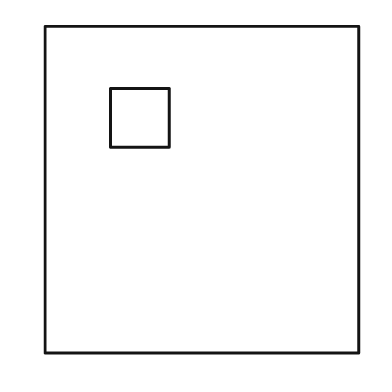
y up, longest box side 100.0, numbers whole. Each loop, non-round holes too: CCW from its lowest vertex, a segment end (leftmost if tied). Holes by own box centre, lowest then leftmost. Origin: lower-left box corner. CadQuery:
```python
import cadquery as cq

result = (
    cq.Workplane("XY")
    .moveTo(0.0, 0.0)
    .lineTo(96.0, 0.0)
    .lineTo(96.0, 100.0)
    .lineTo(0.0, 100.0)
    .close()
    .moveTo(20.0, 63.0)
    .lineTo(38.0, 63.0)
    .lineTo(38.0, 81.0)
    .lineTo(20.0, 81.0)
    .close()
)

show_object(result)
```